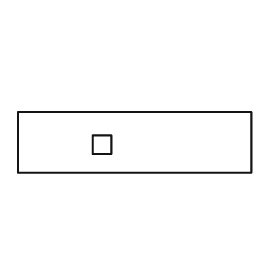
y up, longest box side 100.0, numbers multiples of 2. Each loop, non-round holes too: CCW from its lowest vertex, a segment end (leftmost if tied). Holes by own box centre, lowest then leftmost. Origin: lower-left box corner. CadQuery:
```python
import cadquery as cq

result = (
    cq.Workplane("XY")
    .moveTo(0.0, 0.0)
    .lineTo(100.0, 0.0)
    .lineTo(100.0, 26.0)
    .lineTo(0.0, 26.0)
    .close()
    .moveTo(32.0, 8.0)
    .lineTo(40.0, 8.0)
    .lineTo(40.0, 16.0)
    .lineTo(32.0, 16.0)
    .close()
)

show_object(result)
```